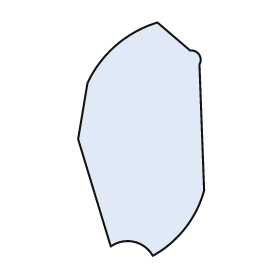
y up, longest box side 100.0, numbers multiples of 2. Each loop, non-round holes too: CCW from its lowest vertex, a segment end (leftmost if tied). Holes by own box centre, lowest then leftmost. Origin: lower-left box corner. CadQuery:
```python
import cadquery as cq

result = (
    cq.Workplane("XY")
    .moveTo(32.0, 0.0)
    .threePointArc((46.0, 12.0), (54.0, 28.0))
    .lineTo(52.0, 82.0)
    .threePointArc((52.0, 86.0), (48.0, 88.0))
    .lineTo(34.0, 100.0)
    .threePointArc((16.0, 90.0), (4.0, 74.0))
    .lineTo(0.0, 50.0)
    .lineTo(14.0, 4.0)
    .threePointArc((24.0, 6.0), (32.0, 0.0))
    .close()
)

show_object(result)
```